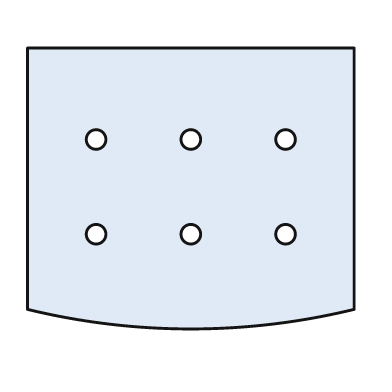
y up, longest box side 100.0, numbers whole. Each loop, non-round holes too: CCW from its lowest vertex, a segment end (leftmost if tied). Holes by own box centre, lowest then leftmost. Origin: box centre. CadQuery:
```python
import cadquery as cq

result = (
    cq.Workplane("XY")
    .moveTo(-50.0, -37.0)
    .threePointArc((0.0, -43.0), (50.0, -37.0))
    .lineTo(50.0, 43.0)
    .lineTo(-50.0, 43.0)
    .close()
    .moveTo(-29.0, -14.0)
    .circle(3.0)
    .moveTo(0.0, -14.0)
    .circle(3.0)
    .moveTo(29.0, -14.0)
    .circle(3.0)
    .moveTo(-29.0, 15.0)
    .circle(3.0)
    .moveTo(0.0, 15.0)
    .circle(3.0)
    .moveTo(29.0, 15.0)
    .circle(3.0)
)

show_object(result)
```